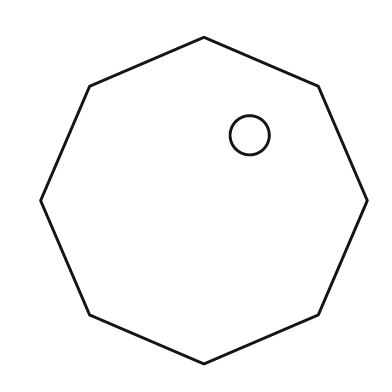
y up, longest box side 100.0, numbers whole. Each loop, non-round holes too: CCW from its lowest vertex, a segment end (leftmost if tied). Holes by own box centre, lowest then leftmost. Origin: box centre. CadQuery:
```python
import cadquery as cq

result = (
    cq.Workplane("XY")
    .moveTo(0.0, -50.0)
    .lineTo(35.0, -35.0)
    .lineTo(50.0, 0.0)
    .lineTo(35.0, 35.0)
    .lineTo(0.0, 50.0)
    .lineTo(-35.0, 35.0)
    .lineTo(-50.0, 0.0)
    .lineTo(-35.0, -35.0)
    .close()
    .moveTo(14.0, 20.0)
    .circle(6.0)
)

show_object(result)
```